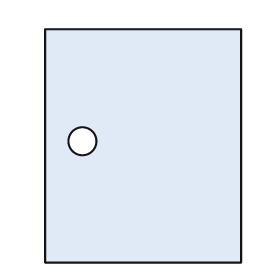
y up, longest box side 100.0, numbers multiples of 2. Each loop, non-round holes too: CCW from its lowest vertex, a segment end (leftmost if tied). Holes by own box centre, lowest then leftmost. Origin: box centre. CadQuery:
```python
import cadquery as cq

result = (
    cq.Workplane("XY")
    .moveTo(-42.0, -50.0)
    .lineTo(42.0, -50.0)
    .lineTo(42.0, 50.0)
    .lineTo(-42.0, 50.0)
    .close()
    .moveTo(-26.0, 2.0)
    .circle(6.0)
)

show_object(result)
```